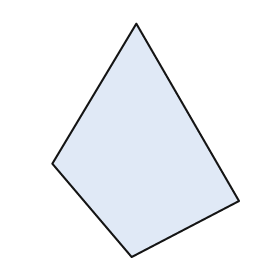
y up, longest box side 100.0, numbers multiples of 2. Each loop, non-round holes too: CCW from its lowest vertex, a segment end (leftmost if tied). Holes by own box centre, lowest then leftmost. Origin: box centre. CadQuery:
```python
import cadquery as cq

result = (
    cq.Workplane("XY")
    .moveTo(-6.0, -50.0)
    .lineTo(40.0, -26.0)
    .lineTo(-4.0, 50.0)
    .lineTo(-40.0, -10.0)
    .close()
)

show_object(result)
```